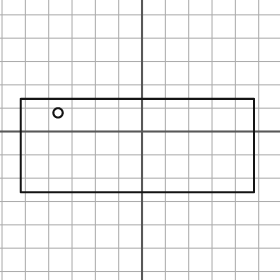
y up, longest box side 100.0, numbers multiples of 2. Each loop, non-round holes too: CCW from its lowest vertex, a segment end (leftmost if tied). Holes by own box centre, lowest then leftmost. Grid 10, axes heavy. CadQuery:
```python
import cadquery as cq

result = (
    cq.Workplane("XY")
    .moveTo(-52.0, -26.0)
    .lineTo(48.0, -26.0)
    .lineTo(48.0, 14.0)
    .lineTo(-52.0, 14.0)
    .close()
    .moveTo(-36.0, 8.0)
    .circle(2.0)
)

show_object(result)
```